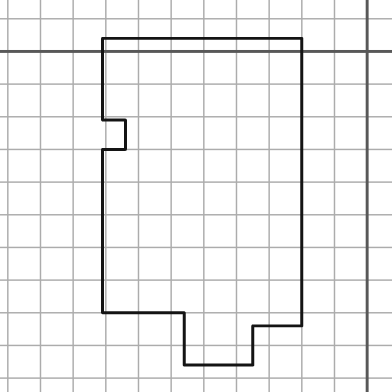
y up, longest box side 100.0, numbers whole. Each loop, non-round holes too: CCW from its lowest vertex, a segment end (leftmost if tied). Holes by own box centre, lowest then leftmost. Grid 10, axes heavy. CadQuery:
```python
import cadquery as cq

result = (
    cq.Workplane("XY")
    .moveTo(-56.0, -96.0)
    .lineTo(-35.0, -96.0)
    .lineTo(-35.0, -84.0)
    .lineTo(-20.0, -84.0)
    .lineTo(-20.0, 4.0)
    .lineTo(-81.0, 4.0)
    .lineTo(-81.0, -21.0)
    .lineTo(-74.0, -21.0)
    .lineTo(-74.0, -30.0)
    .lineTo(-81.0, -30.0)
    .lineTo(-81.0, -80.0)
    .lineTo(-56.0, -80.0)
    .close()
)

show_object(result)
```